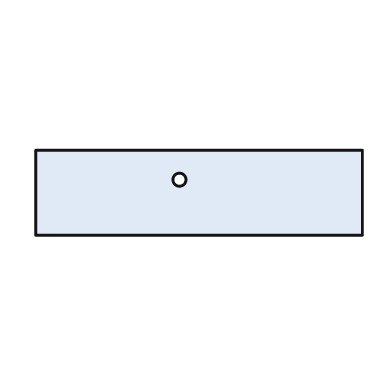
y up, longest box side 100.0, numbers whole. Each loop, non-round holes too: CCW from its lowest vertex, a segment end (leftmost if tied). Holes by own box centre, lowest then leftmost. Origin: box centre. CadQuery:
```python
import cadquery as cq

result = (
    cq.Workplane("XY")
    .moveTo(-50.0, -13.0)
    .lineTo(50.0, -13.0)
    .lineTo(50.0, 13.0)
    .lineTo(-50.0, 13.0)
    .close()
    .moveTo(-6.0, 4.0)
    .circle(2.0)
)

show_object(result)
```